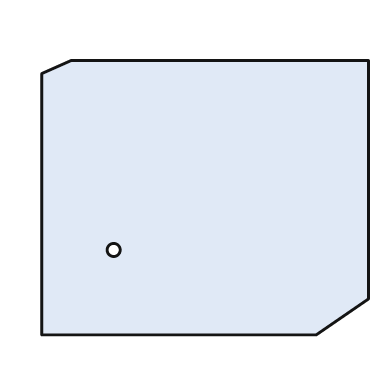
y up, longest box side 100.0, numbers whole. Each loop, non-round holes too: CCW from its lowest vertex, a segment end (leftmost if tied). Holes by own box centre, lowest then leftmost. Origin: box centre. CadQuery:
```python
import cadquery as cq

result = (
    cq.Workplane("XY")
    .moveTo(-50.0, -42.0)
    .lineTo(34.0, -42.0)
    .lineTo(50.0, -31.0)
    .lineTo(50.0, 42.0)
    .lineTo(-41.0, 42.0)
    .lineTo(-50.0, 38.0)
    .close()
    .moveTo(-28.0, -16.0)
    .circle(2.0)
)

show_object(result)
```